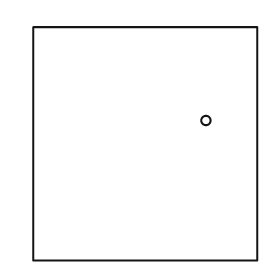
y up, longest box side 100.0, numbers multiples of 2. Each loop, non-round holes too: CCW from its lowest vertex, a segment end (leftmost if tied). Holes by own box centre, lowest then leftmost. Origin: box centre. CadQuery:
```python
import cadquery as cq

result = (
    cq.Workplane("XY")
    .moveTo(-48.0, -50.0)
    .lineTo(48.0, -50.0)
    .lineTo(48.0, 50.0)
    .lineTo(-48.0, 50.0)
    .close()
    .moveTo(26.0, 10.0)
    .circle(2.0)
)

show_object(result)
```